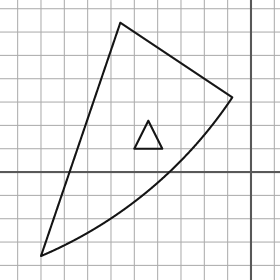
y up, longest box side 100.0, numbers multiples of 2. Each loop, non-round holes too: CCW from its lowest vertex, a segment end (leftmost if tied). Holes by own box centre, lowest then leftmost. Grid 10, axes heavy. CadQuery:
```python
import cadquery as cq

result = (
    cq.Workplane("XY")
    .moveTo(-90.0, -36.0)
    .threePointArc((-44.0, -8.0), (-8.0, 32.0))
    .lineTo(-56.0, 64.0)
    .close()
    .moveTo(-50.0, 10.0)
    .lineTo(-38.0, 10.0)
    .lineTo(-44.0, 22.0)
    .close()
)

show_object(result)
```